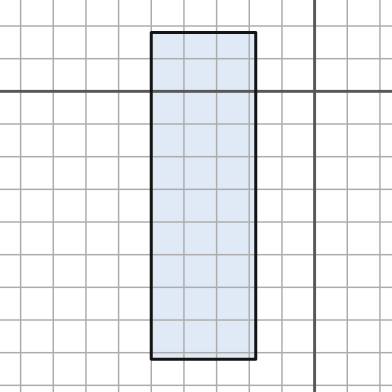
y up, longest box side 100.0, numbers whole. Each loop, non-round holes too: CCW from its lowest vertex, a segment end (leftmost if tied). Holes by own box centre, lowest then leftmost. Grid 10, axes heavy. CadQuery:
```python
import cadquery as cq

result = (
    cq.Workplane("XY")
    .moveTo(-50.0, -82.0)
    .lineTo(-18.0, -82.0)
    .lineTo(-18.0, 18.0)
    .lineTo(-50.0, 18.0)
    .close()
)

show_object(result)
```